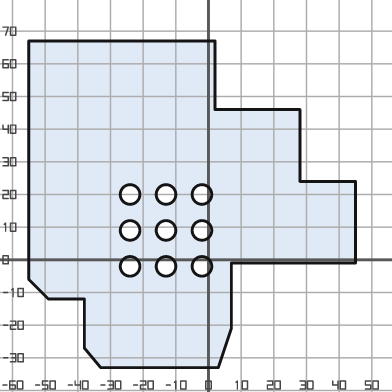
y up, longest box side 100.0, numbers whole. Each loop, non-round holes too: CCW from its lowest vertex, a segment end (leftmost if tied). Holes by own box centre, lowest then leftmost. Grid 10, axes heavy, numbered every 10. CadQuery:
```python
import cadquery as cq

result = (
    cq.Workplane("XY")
    .moveTo(-33.0, -33.0)
    .lineTo(3.0, -33.0)
    .lineTo(7.0, -21.0)
    .lineTo(7.0, -1.0)
    .lineTo(45.0, -1.0)
    .lineTo(45.0, 24.0)
    .lineTo(28.0, 24.0)
    .lineTo(28.0, 46.0)
    .lineTo(2.0, 46.0)
    .lineTo(2.0, 67.0)
    .lineTo(-55.0, 67.0)
    .lineTo(-55.0, -6.0)
    .lineTo(-49.0, -12.0)
    .lineTo(-38.0, -12.0)
    .lineTo(-38.0, -27.0)
    .close()
    .moveTo(-24.0, -2.0)
    .circle(3.0)
    .moveTo(-13.0, -2.0)
    .circle(3.0)
    .moveTo(-2.0, -2.0)
    .circle(3.0)
    .moveTo(-24.0, 9.0)
    .circle(3.0)
    .moveTo(-13.0, 9.0)
    .circle(3.0)
    .moveTo(-2.0, 9.0)
    .circle(3.0)
    .moveTo(-24.0, 20.0)
    .circle(3.0)
    .moveTo(-13.0, 20.0)
    .circle(3.0)
    .moveTo(-2.0, 20.0)
    .circle(3.0)
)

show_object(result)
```